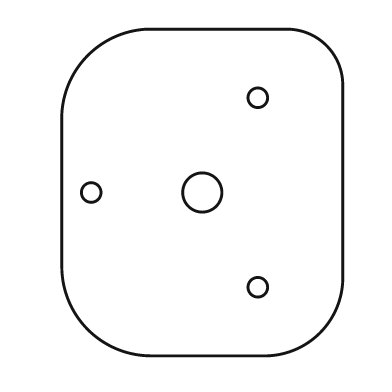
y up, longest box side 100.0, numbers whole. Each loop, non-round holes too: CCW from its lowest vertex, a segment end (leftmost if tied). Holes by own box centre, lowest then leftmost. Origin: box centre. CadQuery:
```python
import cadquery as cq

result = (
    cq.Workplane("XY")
    .moveTo(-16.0, -50.0)
    .lineTo(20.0, -50.0)
    .threePointArc((36.0, -43.0), (43.0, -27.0))
    .lineTo(43.0, 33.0)
    .threePointArc((38.0, 45.0), (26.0, 50.0))
    .lineTo(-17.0, 50.0)
    .threePointArc((-35.0, 42.0), (-43.0, 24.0))
    .lineTo(-43.0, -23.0)
    .threePointArc((-35.0, -42.0), (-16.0, -50.0))
    .close()
    .moveTo(17.0, -29.0)
    .circle(3.0)
    .moveTo(-34.0, 0.0)
    .circle(3.0)
    .moveTo(0.0, 0.0)
    .circle(6.0)
    .moveTo(17.0, 29.0)
    .circle(3.0)
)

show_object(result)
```